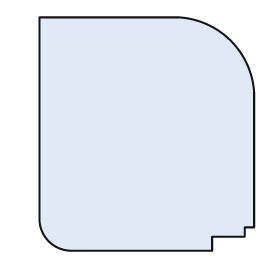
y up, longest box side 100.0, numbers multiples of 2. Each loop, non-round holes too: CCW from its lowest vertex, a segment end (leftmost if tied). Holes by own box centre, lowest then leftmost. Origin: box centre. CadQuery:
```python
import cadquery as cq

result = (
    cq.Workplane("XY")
    .moveTo(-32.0, -50.0)
    .lineTo(28.0, -50.0)
    .lineTo(28.0, -44.0)
    .lineTo(42.0, -44.0)
    .lineTo(42.0, -40.0)
    .lineTo(46.0, -40.0)
    .lineTo(46.0, 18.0)
    .threePointArc((36.0, 40.0), (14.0, 50.0))
    .lineTo(-46.0, 50.0)
    .lineTo(-46.0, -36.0)
    .threePointArc((-42.0, -46.0), (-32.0, -50.0))
    .close()
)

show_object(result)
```